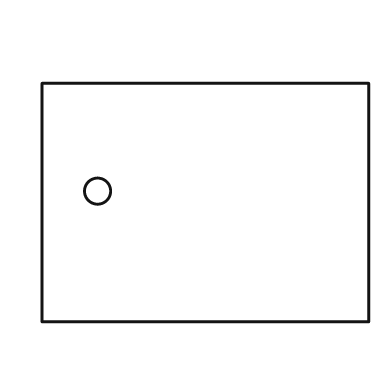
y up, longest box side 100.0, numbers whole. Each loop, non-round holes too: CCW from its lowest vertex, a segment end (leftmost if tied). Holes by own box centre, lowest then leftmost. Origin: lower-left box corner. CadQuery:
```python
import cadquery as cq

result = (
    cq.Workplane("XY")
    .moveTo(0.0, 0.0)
    .lineTo(100.0, 0.0)
    .lineTo(100.0, 73.0)
    .lineTo(0.0, 73.0)
    .close()
    .moveTo(17.0, 40.0)
    .circle(4.0)
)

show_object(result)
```